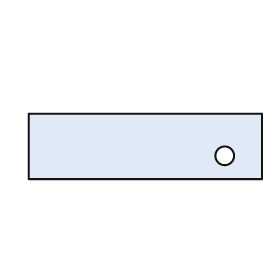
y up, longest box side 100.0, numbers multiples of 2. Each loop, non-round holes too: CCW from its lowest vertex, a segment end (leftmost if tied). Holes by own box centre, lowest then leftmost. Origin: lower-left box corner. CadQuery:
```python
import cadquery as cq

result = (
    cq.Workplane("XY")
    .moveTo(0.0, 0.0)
    .lineTo(100.0, 0.0)
    .lineTo(100.0, 28.0)
    .lineTo(0.0, 28.0)
    .close()
    .moveTo(84.0, 10.0)
    .circle(4.0)
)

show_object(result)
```